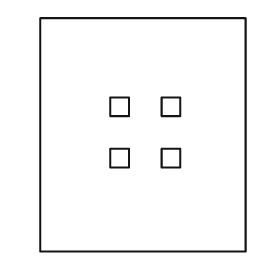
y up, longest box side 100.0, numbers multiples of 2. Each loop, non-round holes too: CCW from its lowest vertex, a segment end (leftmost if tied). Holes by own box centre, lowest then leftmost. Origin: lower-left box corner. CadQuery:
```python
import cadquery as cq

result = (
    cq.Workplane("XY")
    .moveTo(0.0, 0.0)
    .lineTo(88.0, 0.0)
    .lineTo(88.0, 100.0)
    .lineTo(0.0, 100.0)
    .close()
    .moveTo(30.0, 36.0)
    .lineTo(38.0, 36.0)
    .lineTo(38.0, 44.0)
    .lineTo(30.0, 44.0)
    .close()
    .moveTo(52.0, 36.0)
    .lineTo(60.0, 36.0)
    .lineTo(60.0, 44.0)
    .lineTo(52.0, 44.0)
    .close()
    .moveTo(30.0, 58.0)
    .lineTo(38.0, 58.0)
    .lineTo(38.0, 66.0)
    .lineTo(30.0, 66.0)
    .close()
    .moveTo(52.0, 58.0)
    .lineTo(60.0, 58.0)
    .lineTo(60.0, 66.0)
    .lineTo(52.0, 66.0)
    .close()
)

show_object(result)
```